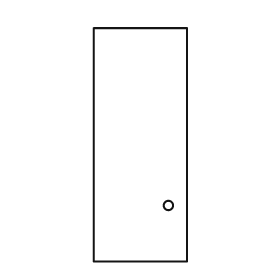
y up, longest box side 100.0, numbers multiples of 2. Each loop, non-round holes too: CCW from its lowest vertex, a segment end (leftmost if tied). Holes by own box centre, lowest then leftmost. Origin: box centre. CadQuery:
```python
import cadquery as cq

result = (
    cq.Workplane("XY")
    .moveTo(-20.0, -50.0)
    .lineTo(20.0, -50.0)
    .lineTo(20.0, 50.0)
    .lineTo(-20.0, 50.0)
    .close()
    .moveTo(12.0, -26.0)
    .circle(2.0)
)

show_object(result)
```